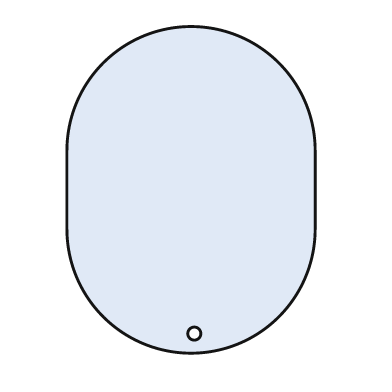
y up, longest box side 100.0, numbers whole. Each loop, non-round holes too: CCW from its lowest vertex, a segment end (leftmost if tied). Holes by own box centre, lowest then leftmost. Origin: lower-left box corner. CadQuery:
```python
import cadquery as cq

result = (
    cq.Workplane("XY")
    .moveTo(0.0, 38.0)
    .threePointArc((38.0, 0.0), (76.0, 38.0))
    .lineTo(76.0, 62.0)
    .threePointArc((38.0, 100.0), (0.0, 62.0))
    .close()
    .moveTo(39.0, 6.0)
    .circle(2.0)
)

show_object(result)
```